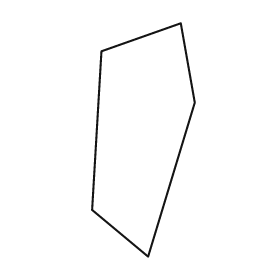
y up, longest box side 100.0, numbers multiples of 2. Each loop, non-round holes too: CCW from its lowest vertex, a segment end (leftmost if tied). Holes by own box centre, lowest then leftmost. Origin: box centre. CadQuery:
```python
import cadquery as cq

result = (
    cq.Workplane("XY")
    .moveTo(2.0, -50.0)
    .lineTo(22.0, 16.0)
    .lineTo(16.0, 50.0)
    .lineTo(-18.0, 38.0)
    .lineTo(-22.0, -30.0)
    .close()
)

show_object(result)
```